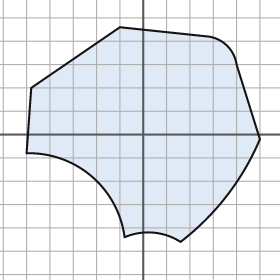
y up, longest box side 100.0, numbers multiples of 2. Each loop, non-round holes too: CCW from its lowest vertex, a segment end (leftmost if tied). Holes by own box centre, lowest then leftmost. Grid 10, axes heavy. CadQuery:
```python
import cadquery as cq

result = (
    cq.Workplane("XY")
    .moveTo(16.0, -46.0)
    .threePointArc((36.0, -26.0), (50.0, -2.0))
    .lineTo(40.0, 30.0)
    .threePointArc((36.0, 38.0), (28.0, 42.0))
    .lineTo(-10.0, 46.0)
    .lineTo(-48.0, 20.0)
    .lineTo(-50.0, -8.0)
    .threePointArc((-22.0, -18.0), (-8.0, -44.0))
    .threePointArc((4.0, -42.0), (16.0, -46.0))
    .close()
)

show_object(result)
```